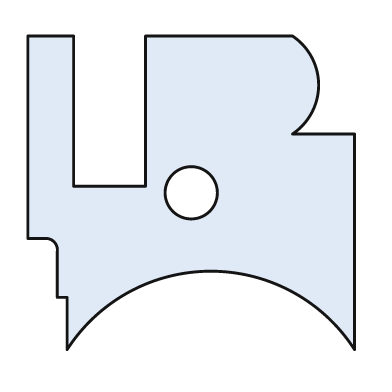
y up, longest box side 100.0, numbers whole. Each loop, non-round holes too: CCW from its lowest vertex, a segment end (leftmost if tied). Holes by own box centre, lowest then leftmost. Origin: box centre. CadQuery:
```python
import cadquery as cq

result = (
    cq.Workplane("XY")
    .moveTo(-38.0, -48.0)
    .threePointArc((6.0, -24.0), (50.0, -48.0))
    .lineTo(50.0, 18.0)
    .lineTo(31.0, 18.0)
    .threePointArc((39.0, 33.0), (31.0, 48.0))
    .lineTo(-14.0, 48.0)
    .lineTo(-14.0, 2.0)
    .lineTo(-36.0, 2.0)
    .lineTo(-36.0, 48.0)
    .lineTo(-50.0, 48.0)
    .lineTo(-50.0, -14.0)
    .lineTo(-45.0, -14.0)
    .threePointArc((-42.0, -15.0), (-41.0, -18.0))
    .lineTo(-41.0, -32.0)
    .lineTo(-38.0, -32.0)
    .close()
    .moveTo(0.0, 0.0)
    .circle(8.0)
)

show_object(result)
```